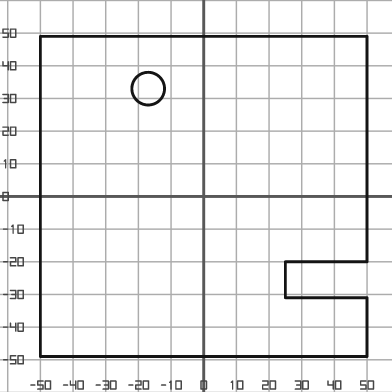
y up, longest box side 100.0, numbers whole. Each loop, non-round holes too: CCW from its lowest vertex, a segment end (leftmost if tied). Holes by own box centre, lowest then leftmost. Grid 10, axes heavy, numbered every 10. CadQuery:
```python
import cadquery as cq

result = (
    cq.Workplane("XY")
    .moveTo(-50.0, -49.0)
    .lineTo(50.0, -49.0)
    .lineTo(50.0, -31.0)
    .lineTo(25.0, -31.0)
    .lineTo(25.0, -20.0)
    .lineTo(50.0, -20.0)
    .lineTo(50.0, 49.0)
    .lineTo(-50.0, 49.0)
    .close()
    .moveTo(-17.0, 33.0)
    .circle(5.0)
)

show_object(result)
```